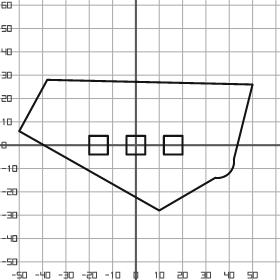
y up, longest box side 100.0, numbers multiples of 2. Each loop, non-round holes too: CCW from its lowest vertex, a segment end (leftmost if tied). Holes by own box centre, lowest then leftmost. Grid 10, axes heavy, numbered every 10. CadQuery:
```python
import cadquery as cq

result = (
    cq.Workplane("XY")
    .moveTo(10.0, -28.0)
    .lineTo(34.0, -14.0)
    .threePointArc((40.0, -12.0), (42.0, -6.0))
    .lineTo(50.0, 26.0)
    .lineTo(-38.0, 28.0)
    .lineTo(-50.0, 6.0)
    .close()
    .moveTo(-20.0, -4.0)
    .lineTo(-12.0, -4.0)
    .lineTo(-12.0, 4.0)
    .lineTo(-20.0, 4.0)
    .close()
    .moveTo(-4.0, -4.0)
    .lineTo(4.0, -4.0)
    .lineTo(4.0, 4.0)
    .lineTo(-4.0, 4.0)
    .close()
    .moveTo(12.0, -4.0)
    .lineTo(20.0, -4.0)
    .lineTo(20.0, 4.0)
    .lineTo(12.0, 4.0)
    .close()
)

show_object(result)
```